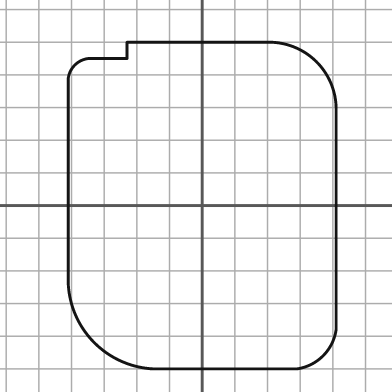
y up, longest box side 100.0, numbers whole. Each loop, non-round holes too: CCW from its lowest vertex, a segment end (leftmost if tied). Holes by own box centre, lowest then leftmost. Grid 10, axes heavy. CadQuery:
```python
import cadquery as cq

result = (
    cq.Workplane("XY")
    .moveTo(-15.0, -50.0)
    .lineTo(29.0, -50.0)
    .threePointArc((37.0, -46.0), (41.0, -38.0))
    .lineTo(41.0, 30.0)
    .threePointArc((35.0, 44.0), (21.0, 50.0))
    .lineTo(-23.0, 50.0)
    .lineTo(-23.0, 45.0)
    .lineTo(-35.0, 45.0)
    .threePointArc((-39.0, 43.0), (-41.0, 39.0))
    .lineTo(-41.0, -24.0)
    .threePointArc((-33.0, -42.0), (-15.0, -50.0))
    .close()
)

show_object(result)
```